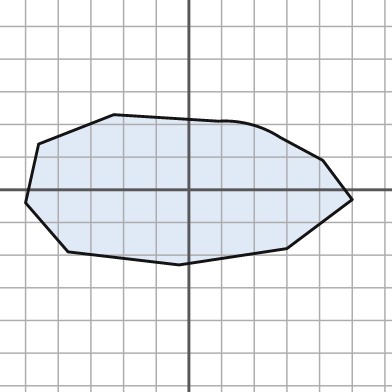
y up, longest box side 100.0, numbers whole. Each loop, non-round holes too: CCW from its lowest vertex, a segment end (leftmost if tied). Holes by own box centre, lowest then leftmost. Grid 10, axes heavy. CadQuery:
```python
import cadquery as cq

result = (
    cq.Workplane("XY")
    .moveTo(-3.0, -23.0)
    .lineTo(30.0, -18.0)
    .lineTo(50.0, -3.0)
    .lineTo(41.0, 9.0)
    .lineTo(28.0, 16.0)
    .threePointArc((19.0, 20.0), (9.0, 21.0))
    .lineTo(-23.0, 23.0)
    .lineTo(-46.0, 14.0)
    .lineTo(-50.0, -4.0)
    .lineTo(-37.0, -19.0)
    .close()
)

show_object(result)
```